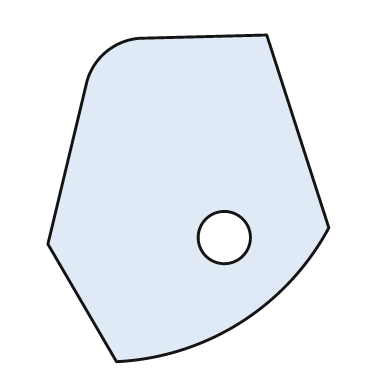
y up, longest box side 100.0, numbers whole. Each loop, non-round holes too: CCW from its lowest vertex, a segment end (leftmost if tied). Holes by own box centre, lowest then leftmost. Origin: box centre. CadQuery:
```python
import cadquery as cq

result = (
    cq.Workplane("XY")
    .moveTo(-22.0, -50.0)
    .threePointArc((16.0, -38.0), (43.0, -9.0))
    .lineTo(24.0, 50.0)
    .lineTo(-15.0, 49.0)
    .threePointArc((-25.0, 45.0), (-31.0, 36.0))
    .lineTo(-43.0, -14.0)
    .close()
    .moveTo(11.0, -12.0)
    .circle(8.0)
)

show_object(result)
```